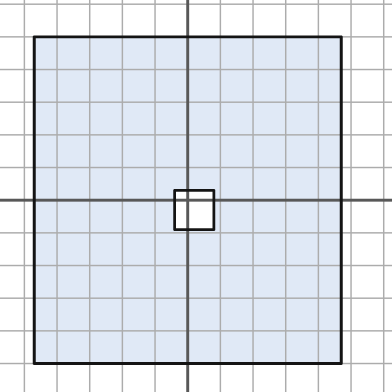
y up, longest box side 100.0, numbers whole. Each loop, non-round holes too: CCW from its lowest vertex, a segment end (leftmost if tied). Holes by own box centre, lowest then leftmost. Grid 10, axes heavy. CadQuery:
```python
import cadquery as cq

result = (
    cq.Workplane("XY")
    .moveTo(-47.0, -50.0)
    .lineTo(47.0, -50.0)
    .lineTo(47.0, 50.0)
    .lineTo(-47.0, 50.0)
    .close()
    .moveTo(-4.0, -9.0)
    .lineTo(8.0, -9.0)
    .lineTo(8.0, 3.0)
    .lineTo(-4.0, 3.0)
    .close()
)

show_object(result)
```